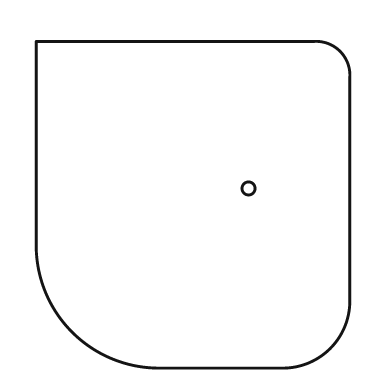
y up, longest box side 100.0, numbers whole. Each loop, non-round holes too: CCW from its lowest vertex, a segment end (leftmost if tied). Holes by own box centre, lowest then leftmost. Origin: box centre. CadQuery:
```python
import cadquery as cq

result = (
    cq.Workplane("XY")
    .moveTo(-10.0, -50.0)
    .lineTo(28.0, -50.0)
    .threePointArc((42.0, -44.0), (48.0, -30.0))
    .lineTo(48.0, 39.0)
    .threePointArc((45.0, 47.0), (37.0, 50.0))
    .lineTo(-48.0, 50.0)
    .lineTo(-48.0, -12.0)
    .threePointArc((-37.0, -39.0), (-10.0, -50.0))
    .close()
    .moveTo(17.0, 5.0)
    .circle(2.0)
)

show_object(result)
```